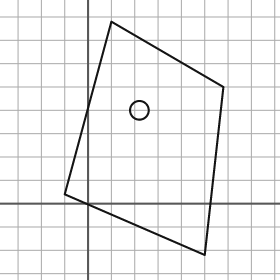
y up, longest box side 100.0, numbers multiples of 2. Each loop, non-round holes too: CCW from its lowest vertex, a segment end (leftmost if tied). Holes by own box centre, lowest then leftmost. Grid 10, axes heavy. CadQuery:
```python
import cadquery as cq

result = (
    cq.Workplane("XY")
    .moveTo(50.0, -22.0)
    .lineTo(58.0, 50.0)
    .lineTo(10.0, 78.0)
    .lineTo(-10.0, 4.0)
    .close()
    .moveTo(22.0, 40.0)
    .circle(4.0)
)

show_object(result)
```